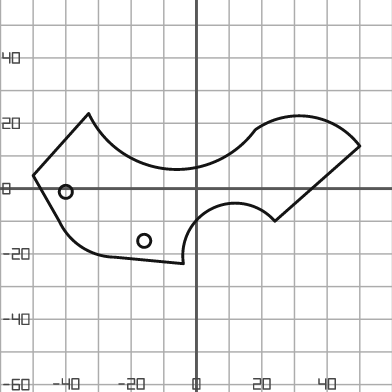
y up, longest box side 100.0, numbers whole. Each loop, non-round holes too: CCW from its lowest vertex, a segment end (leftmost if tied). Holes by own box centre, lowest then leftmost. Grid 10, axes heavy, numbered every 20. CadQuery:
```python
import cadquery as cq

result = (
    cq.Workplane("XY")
    .moveTo(-4.0, -23.0)
    .threePointArc((5.0, -6.0), (24.0, -10.0))
    .lineTo(50.0, 13.0)
    .threePointArc((35.0, 22.0), (18.0, 18.0))
    .threePointArc((-9.0, 6.0), (-33.0, 23.0))
    .lineTo(-50.0, 4.0)
    .lineTo(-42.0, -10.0)
    .threePointArc((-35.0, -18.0), (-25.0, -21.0))
    .close()
    .moveTo(-16.0, -16.0)
    .circle(2.0)
    .moveTo(-40.0, -1.0)
    .circle(2.0)
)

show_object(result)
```